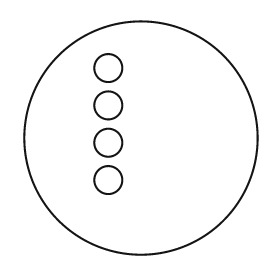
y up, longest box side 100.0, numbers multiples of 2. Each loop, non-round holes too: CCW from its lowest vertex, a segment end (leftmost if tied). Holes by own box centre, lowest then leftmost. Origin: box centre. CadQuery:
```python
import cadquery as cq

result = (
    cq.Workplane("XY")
    .moveTo(0.0, 0.0)
    .circle(50.0)
    .moveTo(-14.0, -18.0)
    .circle(6.0)
    .moveTo(-14.0, -2.0)
    .circle(6.0)
    .moveTo(-14.0, 14.0)
    .circle(6.0)
    .moveTo(-14.0, 30.0)
    .circle(6.0)
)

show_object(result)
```